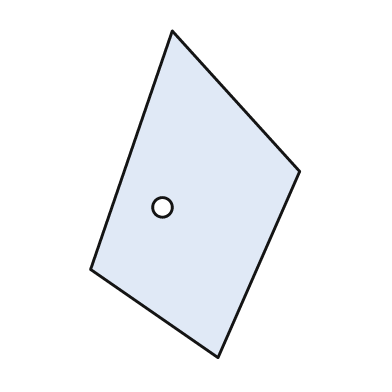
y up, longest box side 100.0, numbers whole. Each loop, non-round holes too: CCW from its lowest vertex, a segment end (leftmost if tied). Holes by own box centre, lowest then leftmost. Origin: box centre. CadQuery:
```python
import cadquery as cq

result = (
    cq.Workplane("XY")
    .moveTo(7.0, -50.0)
    .lineTo(32.0, 7.0)
    .lineTo(-7.0, 50.0)
    .lineTo(-32.0, -23.0)
    .close()
    .moveTo(-10.0, -4.0)
    .circle(3.0)
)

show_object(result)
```